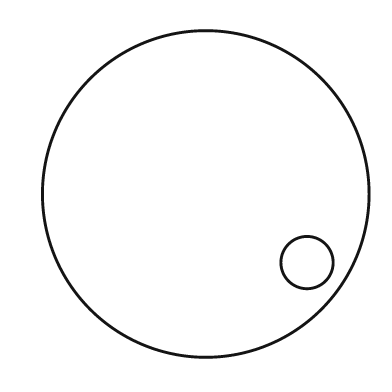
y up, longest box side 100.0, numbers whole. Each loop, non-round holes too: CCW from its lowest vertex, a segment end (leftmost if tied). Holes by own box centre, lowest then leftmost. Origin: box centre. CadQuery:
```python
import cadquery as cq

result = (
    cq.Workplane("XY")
    .moveTo(0.0, 0.0)
    .circle(50.0)
    .moveTo(31.0, -21.0)
    .circle(8.0)
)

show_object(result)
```